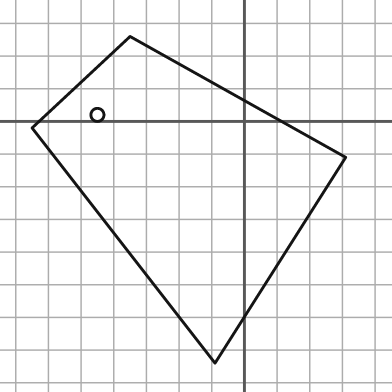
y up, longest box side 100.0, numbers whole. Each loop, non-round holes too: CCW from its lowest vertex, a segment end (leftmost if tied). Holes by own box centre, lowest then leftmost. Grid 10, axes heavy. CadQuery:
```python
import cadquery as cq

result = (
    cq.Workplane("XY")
    .moveTo(-9.0, -74.0)
    .lineTo(31.0, -11.0)
    .lineTo(-35.0, 26.0)
    .lineTo(-65.0, -2.0)
    .close()
    .moveTo(-45.0, 2.0)
    .circle(2.0)
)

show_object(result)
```